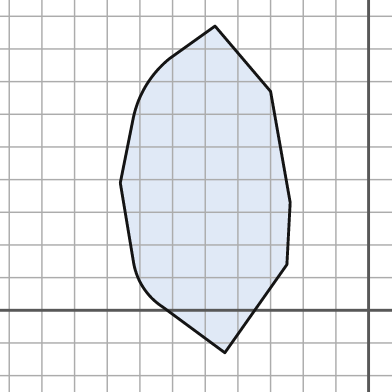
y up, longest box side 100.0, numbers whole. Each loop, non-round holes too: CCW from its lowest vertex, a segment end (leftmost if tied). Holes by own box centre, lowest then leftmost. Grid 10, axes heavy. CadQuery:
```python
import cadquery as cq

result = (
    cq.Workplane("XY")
    .moveTo(-44.0, -13.0)
    .lineTo(-25.0, 14.0)
    .lineTo(-24.0, 33.0)
    .lineTo(-30.0, 67.0)
    .lineTo(-47.0, 87.0)
    .lineTo(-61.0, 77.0)
    .threePointArc((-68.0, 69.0), (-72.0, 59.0))
    .lineTo(-76.0, 39.0)
    .lineTo(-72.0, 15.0)
    .threePointArc((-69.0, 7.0), (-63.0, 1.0))
    .close()
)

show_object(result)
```